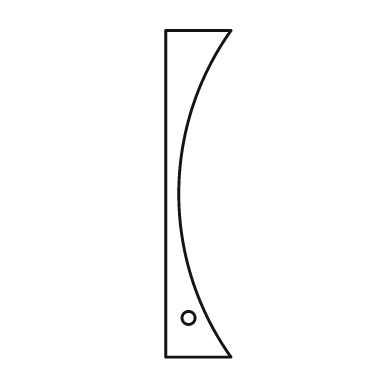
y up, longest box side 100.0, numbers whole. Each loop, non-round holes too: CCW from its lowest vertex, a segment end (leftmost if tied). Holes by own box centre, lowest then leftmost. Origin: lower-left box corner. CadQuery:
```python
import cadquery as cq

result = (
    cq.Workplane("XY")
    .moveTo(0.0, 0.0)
    .lineTo(20.0, 0.0)
    .threePointArc((4.0, 50.0), (20.0, 100.0))
    .lineTo(0.0, 100.0)
    .close()
    .moveTo(7.0, 12.0)
    .circle(2.0)
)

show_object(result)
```